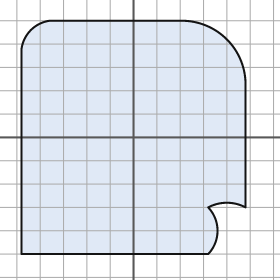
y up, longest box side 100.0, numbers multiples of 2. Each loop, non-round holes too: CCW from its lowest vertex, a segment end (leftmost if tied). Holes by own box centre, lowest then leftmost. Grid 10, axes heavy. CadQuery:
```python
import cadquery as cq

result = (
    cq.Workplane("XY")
    .moveTo(-48.0, -50.0)
    .lineTo(32.0, -50.0)
    .threePointArc((36.0, -40.0), (32.0, -30.0))
    .threePointArc((40.0, -28.0), (48.0, -30.0))
    .lineTo(48.0, 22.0)
    .threePointArc((40.0, 42.0), (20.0, 50.0))
    .lineTo(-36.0, 50.0)
    .threePointArc((-44.0, 46.0), (-48.0, 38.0))
    .close()
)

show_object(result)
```